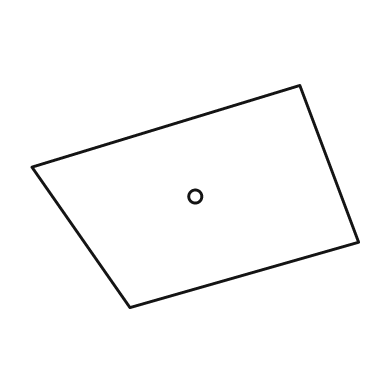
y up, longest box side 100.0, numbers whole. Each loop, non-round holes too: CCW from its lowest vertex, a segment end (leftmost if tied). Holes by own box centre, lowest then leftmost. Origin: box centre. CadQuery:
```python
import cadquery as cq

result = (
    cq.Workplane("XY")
    .moveTo(-20.0, -34.0)
    .lineTo(50.0, -14.0)
    .lineTo(32.0, 34.0)
    .lineTo(-50.0, 9.0)
    .close()
    .moveTo(0.0, 0.0)
    .circle(2.0)
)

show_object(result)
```